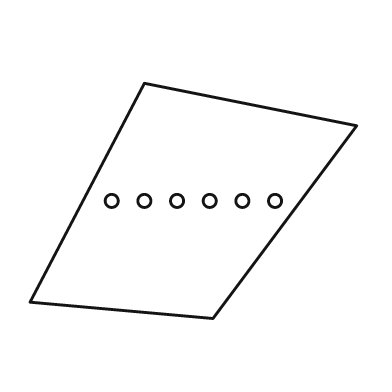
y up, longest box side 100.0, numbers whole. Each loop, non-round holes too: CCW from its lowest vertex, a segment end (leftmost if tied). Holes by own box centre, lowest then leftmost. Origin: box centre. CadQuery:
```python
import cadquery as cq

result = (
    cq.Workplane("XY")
    .moveTo(6.0, -36.0)
    .lineTo(50.0, 23.0)
    .lineTo(-15.0, 36.0)
    .lineTo(-50.0, -31.0)
    .close()
    .moveTo(-25.0, 0.0)
    .circle(2.0)
    .moveTo(-15.0, 0.0)
    .circle(2.0)
    .moveTo(-5.0, 0.0)
    .circle(2.0)
    .moveTo(5.0, 0.0)
    .circle(2.0)
    .moveTo(15.0, 0.0)
    .circle(2.0)
    .moveTo(25.0, 0.0)
    .circle(2.0)
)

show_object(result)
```